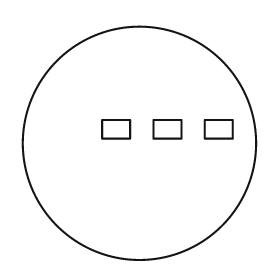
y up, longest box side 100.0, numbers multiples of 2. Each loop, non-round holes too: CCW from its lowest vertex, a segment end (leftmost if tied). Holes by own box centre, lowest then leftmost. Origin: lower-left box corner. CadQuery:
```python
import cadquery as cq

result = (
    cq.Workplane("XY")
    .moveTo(50.0, 50.0)
    .circle(50.0)
    .moveTo(34.0, 52.0)
    .lineTo(46.0, 52.0)
    .lineTo(46.0, 60.0)
    .lineTo(34.0, 60.0)
    .close()
    .moveTo(56.0, 52.0)
    .lineTo(68.0, 52.0)
    .lineTo(68.0, 60.0)
    .lineTo(56.0, 60.0)
    .close()
    .moveTo(78.0, 52.0)
    .lineTo(90.0, 52.0)
    .lineTo(90.0, 60.0)
    .lineTo(78.0, 60.0)
    .close()
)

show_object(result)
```